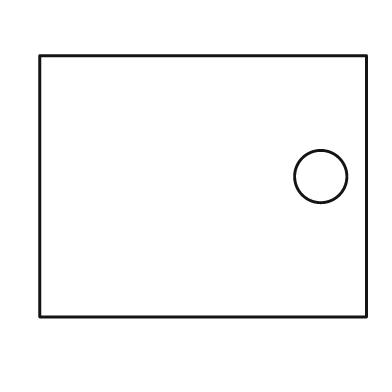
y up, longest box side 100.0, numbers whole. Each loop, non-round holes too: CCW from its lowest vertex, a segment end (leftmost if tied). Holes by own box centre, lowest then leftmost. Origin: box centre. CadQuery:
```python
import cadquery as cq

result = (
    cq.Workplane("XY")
    .moveTo(-50.0, -40.0)
    .lineTo(50.0, -40.0)
    .lineTo(50.0, 40.0)
    .lineTo(-50.0, 40.0)
    .close()
    .moveTo(36.0, 3.0)
    .circle(8.0)
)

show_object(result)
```